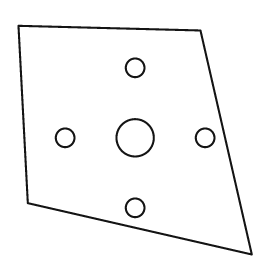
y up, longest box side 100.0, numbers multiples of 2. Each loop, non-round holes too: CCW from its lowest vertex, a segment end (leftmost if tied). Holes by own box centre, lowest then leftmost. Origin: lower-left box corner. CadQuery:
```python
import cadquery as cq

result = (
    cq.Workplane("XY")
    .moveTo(100.0, 0.0)
    .lineTo(78.0, 96.0)
    .lineTo(0.0, 98.0)
    .lineTo(4.0, 22.0)
    .close()
    .moveTo(50.0, 20.0)
    .circle(4.0)
    .moveTo(20.0, 50.0)
    .circle(4.0)
    .moveTo(50.0, 50.0)
    .circle(8.0)
    .moveTo(80.0, 50.0)
    .circle(4.0)
    .moveTo(50.0, 80.0)
    .circle(4.0)
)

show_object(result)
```